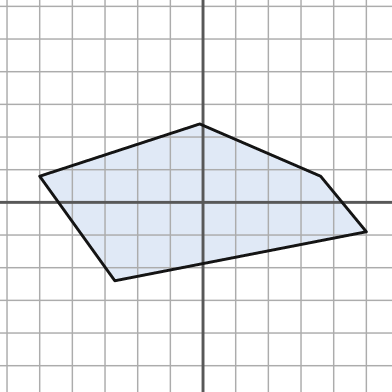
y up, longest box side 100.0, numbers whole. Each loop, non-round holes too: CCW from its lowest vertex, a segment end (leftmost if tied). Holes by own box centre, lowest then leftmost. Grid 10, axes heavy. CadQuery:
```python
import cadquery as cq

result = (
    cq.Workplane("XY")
    .moveTo(-27.0, -24.0)
    .lineTo(50.0, -9.0)
    .lineTo(36.0, 8.0)
    .lineTo(-1.0, 24.0)
    .lineTo(-50.0, 8.0)
    .close()
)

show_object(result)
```